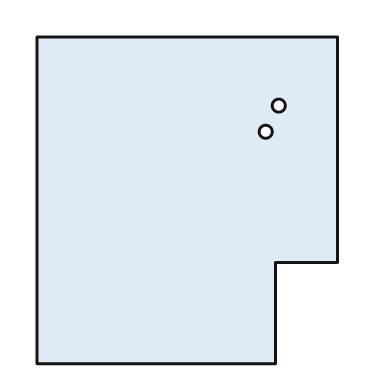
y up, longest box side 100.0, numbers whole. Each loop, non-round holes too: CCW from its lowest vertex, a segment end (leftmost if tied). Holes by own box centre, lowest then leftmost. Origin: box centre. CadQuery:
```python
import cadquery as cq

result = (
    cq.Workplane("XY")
    .moveTo(-46.0, -50.0)
    .lineTo(27.0, -50.0)
    .lineTo(27.0, -19.0)
    .lineTo(46.0, -19.0)
    .lineTo(46.0, 50.0)
    .lineTo(-46.0, 50.0)
    .close()
    .moveTo(24.0, 21.0)
    .circle(2.0)
    .moveTo(28.0, 29.0)
    .circle(2.0)
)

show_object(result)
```